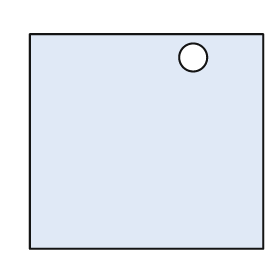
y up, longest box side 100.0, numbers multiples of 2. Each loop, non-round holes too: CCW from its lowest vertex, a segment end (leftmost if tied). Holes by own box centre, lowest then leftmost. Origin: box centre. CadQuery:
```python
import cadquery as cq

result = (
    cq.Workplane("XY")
    .moveTo(-50.0, -46.0)
    .lineTo(50.0, -46.0)
    .lineTo(50.0, 46.0)
    .lineTo(-50.0, 46.0)
    .close()
    .moveTo(20.0, 36.0)
    .circle(6.0)
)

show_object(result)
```